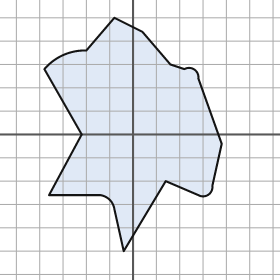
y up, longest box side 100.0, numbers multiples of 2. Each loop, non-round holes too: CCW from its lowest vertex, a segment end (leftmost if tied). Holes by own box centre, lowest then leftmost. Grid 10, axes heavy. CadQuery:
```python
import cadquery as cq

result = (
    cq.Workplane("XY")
    .moveTo(-4.0, -50.0)
    .lineTo(14.0, -20.0)
    .lineTo(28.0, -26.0)
    .threePointArc((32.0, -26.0), (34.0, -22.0))
    .lineTo(38.0, -4.0)
    .lineTo(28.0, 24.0)
    .threePointArc((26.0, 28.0), (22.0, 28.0))
    .lineTo(16.0, 30.0)
    .lineTo(4.0, 44.0)
    .lineTo(-8.0, 50.0)
    .lineTo(-20.0, 36.0)
    .threePointArc((-30.0, 34.0), (-38.0, 28.0))
    .lineTo(-22.0, 0.0)
    .lineTo(-36.0, -26.0)
    .lineTo(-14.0, -26.0)
    .threePointArc((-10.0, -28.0), (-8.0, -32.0))
    .close()
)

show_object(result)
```